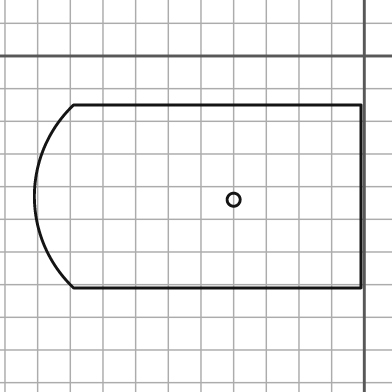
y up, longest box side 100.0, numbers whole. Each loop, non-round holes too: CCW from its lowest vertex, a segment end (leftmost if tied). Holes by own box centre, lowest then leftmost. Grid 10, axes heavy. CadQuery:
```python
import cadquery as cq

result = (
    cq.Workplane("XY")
    .moveTo(-89.0, -71.0)
    .lineTo(-1.0, -71.0)
    .lineTo(-1.0, -15.0)
    .lineTo(-89.0, -15.0)
    .threePointArc((-101.0, -43.0), (-89.0, -71.0))
    .close()
    .moveTo(-40.0, -44.0)
    .circle(2.0)
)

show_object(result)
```